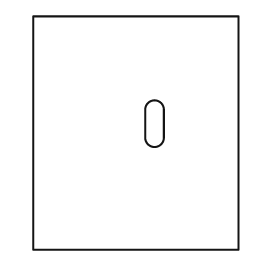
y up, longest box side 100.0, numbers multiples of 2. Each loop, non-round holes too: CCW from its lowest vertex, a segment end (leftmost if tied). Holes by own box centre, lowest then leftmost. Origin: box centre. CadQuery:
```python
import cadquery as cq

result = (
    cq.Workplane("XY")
    .moveTo(-44.0, -50.0)
    .lineTo(44.0, -50.0)
    .lineTo(44.0, 50.0)
    .lineTo(-44.0, 50.0)
    .close()
    .moveTo(4.0, -2.0)
    .threePointArc((8.0, -6.0), (12.0, -2.0))
    .lineTo(12.0, 10.0)
    .threePointArc((8.0, 14.0), (4.0, 10.0))
    .close()
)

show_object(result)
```